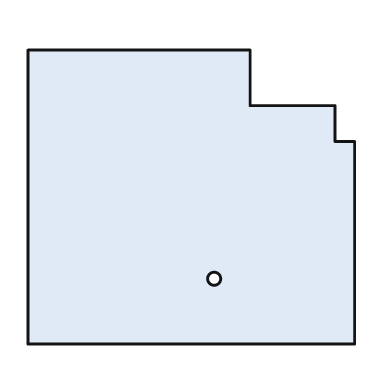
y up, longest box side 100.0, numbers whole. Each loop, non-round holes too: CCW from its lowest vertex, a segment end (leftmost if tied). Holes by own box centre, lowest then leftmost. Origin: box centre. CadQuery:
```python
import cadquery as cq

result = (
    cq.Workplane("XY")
    .moveTo(-50.0, -45.0)
    .lineTo(50.0, -45.0)
    .lineTo(50.0, 17.0)
    .lineTo(44.0, 17.0)
    .lineTo(44.0, 28.0)
    .lineTo(18.0, 28.0)
    .lineTo(18.0, 45.0)
    .lineTo(-50.0, 45.0)
    .close()
    .moveTo(7.0, -25.0)
    .circle(2.0)
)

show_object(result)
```